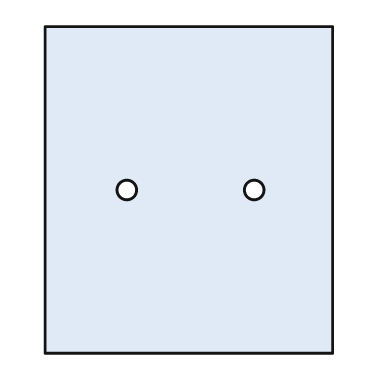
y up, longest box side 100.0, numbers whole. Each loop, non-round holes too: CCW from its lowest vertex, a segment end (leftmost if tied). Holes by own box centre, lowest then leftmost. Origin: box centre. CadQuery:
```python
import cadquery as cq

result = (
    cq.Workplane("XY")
    .moveTo(-44.0, -50.0)
    .lineTo(44.0, -50.0)
    .lineTo(44.0, 50.0)
    .lineTo(-44.0, 50.0)
    .close()
    .moveTo(-19.0, 0.0)
    .circle(3.0)
    .moveTo(20.0, 0.0)
    .circle(3.0)
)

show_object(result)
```